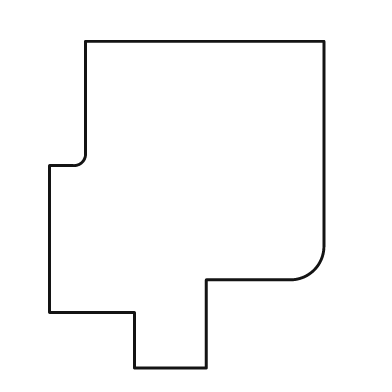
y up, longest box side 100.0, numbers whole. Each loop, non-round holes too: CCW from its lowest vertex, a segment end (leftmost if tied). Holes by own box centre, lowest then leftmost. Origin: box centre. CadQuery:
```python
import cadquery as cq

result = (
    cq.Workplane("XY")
    .moveTo(-16.0, -50.0)
    .lineTo(6.0, -50.0)
    .lineTo(6.0, -23.0)
    .lineTo(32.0, -23.0)
    .threePointArc((39.0, -20.0), (42.0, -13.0))
    .lineTo(42.0, 50.0)
    .lineTo(-31.0, 50.0)
    .lineTo(-31.0, 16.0)
    .threePointArc((-32.0, 13.0), (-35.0, 12.0))
    .lineTo(-42.0, 12.0)
    .lineTo(-42.0, -33.0)
    .lineTo(-16.0, -33.0)
    .close()
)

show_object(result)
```